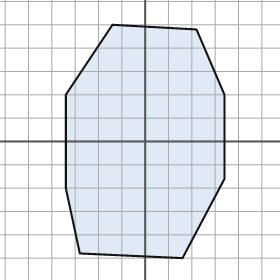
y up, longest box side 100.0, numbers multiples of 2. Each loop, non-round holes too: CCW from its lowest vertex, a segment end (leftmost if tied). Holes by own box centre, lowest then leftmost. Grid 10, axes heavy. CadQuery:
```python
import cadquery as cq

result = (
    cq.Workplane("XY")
    .moveTo(16.0, -50.0)
    .lineTo(34.0, -16.0)
    .lineTo(34.0, 20.0)
    .lineTo(22.0, 48.0)
    .lineTo(-14.0, 50.0)
    .lineTo(-34.0, 20.0)
    .lineTo(-34.0, -20.0)
    .lineTo(-28.0, -48.0)
    .close()
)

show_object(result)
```